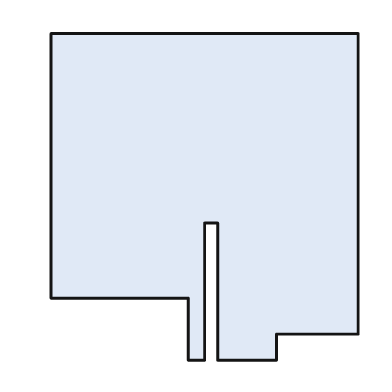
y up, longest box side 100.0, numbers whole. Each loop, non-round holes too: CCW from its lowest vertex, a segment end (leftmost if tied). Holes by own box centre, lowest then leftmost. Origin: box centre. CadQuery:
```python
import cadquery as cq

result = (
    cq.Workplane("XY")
    .moveTo(-5.0, -50.0)
    .lineTo(0.0, -50.0)
    .lineTo(0.0, -8.0)
    .lineTo(4.0, -8.0)
    .lineTo(4.0, -50.0)
    .lineTo(22.0, -50.0)
    .lineTo(22.0, -42.0)
    .lineTo(47.0, -42.0)
    .lineTo(47.0, 50.0)
    .lineTo(-47.0, 50.0)
    .lineTo(-47.0, -31.0)
    .lineTo(-5.0, -31.0)
    .close()
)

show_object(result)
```